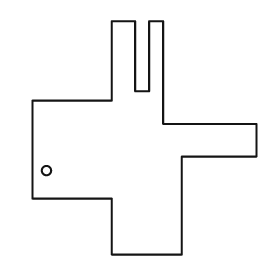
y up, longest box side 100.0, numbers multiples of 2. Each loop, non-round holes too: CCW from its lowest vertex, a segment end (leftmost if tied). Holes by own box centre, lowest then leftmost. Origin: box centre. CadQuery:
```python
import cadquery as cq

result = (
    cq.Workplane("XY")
    .moveTo(-14.0, -50.0)
    .lineTo(16.0, -50.0)
    .lineTo(16.0, -8.0)
    .lineTo(48.0, -8.0)
    .lineTo(48.0, 6.0)
    .lineTo(8.0, 6.0)
    .lineTo(8.0, 50.0)
    .lineTo(2.0, 50.0)
    .lineTo(2.0, 20.0)
    .lineTo(-4.0, 20.0)
    .lineTo(-4.0, 50.0)
    .lineTo(-14.0, 50.0)
    .lineTo(-14.0, 16.0)
    .lineTo(-48.0, 16.0)
    .lineTo(-48.0, -26.0)
    .lineTo(-14.0, -26.0)
    .close()
    .moveTo(-42.0, -14.0)
    .circle(2.0)
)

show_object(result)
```